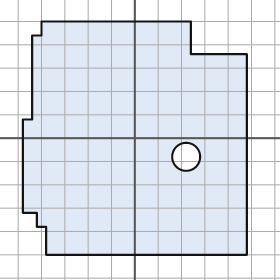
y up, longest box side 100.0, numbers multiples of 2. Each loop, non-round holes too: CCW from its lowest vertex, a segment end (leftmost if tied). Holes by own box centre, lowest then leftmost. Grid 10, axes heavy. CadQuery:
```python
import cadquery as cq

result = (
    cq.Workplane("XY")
    .moveTo(-38.0, -50.0)
    .lineTo(48.0, -50.0)
    .lineTo(48.0, 36.0)
    .lineTo(24.0, 36.0)
    .lineTo(24.0, 50.0)
    .lineTo(-40.0, 50.0)
    .lineTo(-40.0, 44.0)
    .lineTo(-44.0, 44.0)
    .lineTo(-44.0, 8.0)
    .lineTo(-48.0, 8.0)
    .lineTo(-48.0, -32.0)
    .lineTo(-42.0, -32.0)
    .lineTo(-42.0, -38.0)
    .lineTo(-38.0, -38.0)
    .close()
    .moveTo(22.0, -8.0)
    .circle(6.0)
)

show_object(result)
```